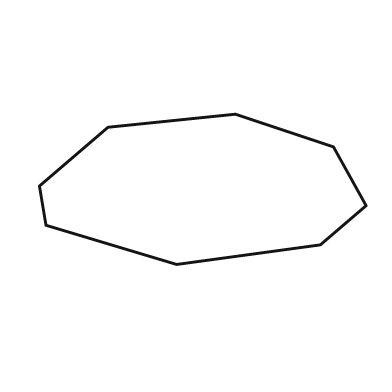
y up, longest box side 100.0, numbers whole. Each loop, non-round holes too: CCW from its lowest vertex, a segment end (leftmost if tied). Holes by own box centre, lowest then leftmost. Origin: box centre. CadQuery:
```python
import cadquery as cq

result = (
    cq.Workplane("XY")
    .moveTo(-8.0, -23.0)
    .lineTo(36.0, -17.0)
    .lineTo(50.0, -5.0)
    .lineTo(40.0, 13.0)
    .lineTo(10.0, 23.0)
    .lineTo(-29.0, 19.0)
    .lineTo(-50.0, 1.0)
    .lineTo(-48.0, -11.0)
    .close()
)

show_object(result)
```